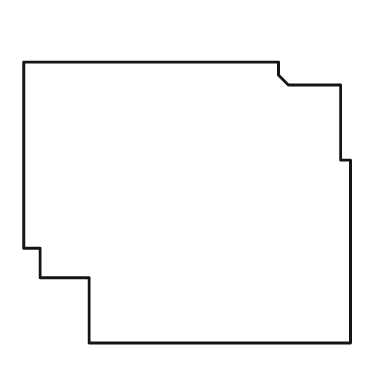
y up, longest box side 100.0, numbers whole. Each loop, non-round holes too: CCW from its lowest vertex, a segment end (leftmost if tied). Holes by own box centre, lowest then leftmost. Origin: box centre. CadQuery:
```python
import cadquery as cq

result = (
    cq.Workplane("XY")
    .moveTo(-30.0, -43.0)
    .lineTo(50.0, -43.0)
    .lineTo(50.0, 13.0)
    .lineTo(47.0, 13.0)
    .lineTo(47.0, 36.0)
    .lineTo(31.0, 36.0)
    .lineTo(28.0, 39.0)
    .lineTo(28.0, 43.0)
    .lineTo(-50.0, 43.0)
    .lineTo(-50.0, -14.0)
    .lineTo(-45.0, -14.0)
    .lineTo(-45.0, -23.0)
    .lineTo(-30.0, -23.0)
    .close()
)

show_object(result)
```